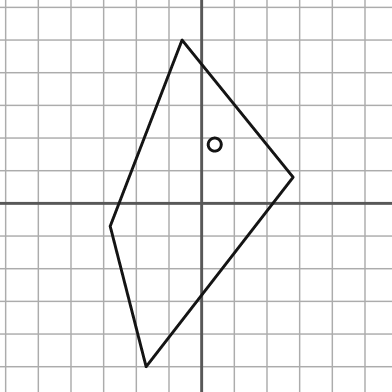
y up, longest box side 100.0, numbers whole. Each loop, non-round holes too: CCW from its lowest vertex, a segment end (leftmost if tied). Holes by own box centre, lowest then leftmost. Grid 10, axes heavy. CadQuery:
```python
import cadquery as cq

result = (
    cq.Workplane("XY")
    .moveTo(-17.0, -50.0)
    .lineTo(28.0, 8.0)
    .lineTo(-6.0, 50.0)
    .lineTo(-28.0, -7.0)
    .close()
    .moveTo(4.0, 18.0)
    .circle(2.0)
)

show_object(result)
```